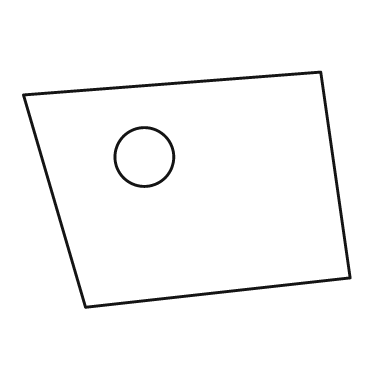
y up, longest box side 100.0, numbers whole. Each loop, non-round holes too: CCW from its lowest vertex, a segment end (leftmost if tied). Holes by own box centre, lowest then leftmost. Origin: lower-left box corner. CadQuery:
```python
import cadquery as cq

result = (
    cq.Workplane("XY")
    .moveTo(19.0, 0.0)
    .lineTo(100.0, 9.0)
    .lineTo(91.0, 72.0)
    .lineTo(0.0, 65.0)
    .close()
    .moveTo(37.0, 46.0)
    .circle(9.0)
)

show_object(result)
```